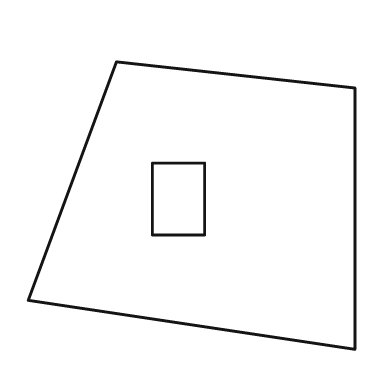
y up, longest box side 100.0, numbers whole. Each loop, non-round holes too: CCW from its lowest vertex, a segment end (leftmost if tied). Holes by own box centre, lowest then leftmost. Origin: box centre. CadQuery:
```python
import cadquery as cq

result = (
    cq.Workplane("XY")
    .moveTo(50.0, -44.0)
    .lineTo(50.0, 36.0)
    .lineTo(-23.0, 44.0)
    .lineTo(-50.0, -29.0)
    .close()
    .moveTo(-12.0, -9.0)
    .lineTo(4.0, -9.0)
    .lineTo(4.0, 13.0)
    .lineTo(-12.0, 13.0)
    .close()
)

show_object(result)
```